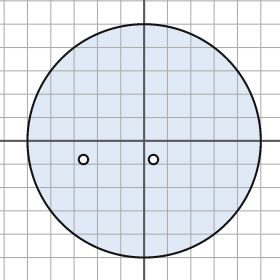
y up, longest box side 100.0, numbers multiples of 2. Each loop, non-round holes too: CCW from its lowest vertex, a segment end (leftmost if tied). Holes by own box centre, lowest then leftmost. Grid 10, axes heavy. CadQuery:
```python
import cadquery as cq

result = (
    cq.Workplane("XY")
    .moveTo(0.0, 0.0)
    .circle(50.0)
    .moveTo(-26.0, -8.0)
    .circle(2.0)
    .moveTo(4.0, -8.0)
    .circle(2.0)
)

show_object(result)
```